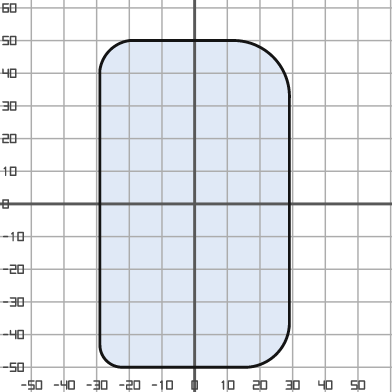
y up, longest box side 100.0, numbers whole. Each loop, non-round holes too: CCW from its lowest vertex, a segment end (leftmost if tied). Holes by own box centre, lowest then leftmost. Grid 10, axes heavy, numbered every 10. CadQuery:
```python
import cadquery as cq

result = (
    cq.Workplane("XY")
    .moveTo(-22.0, -50.0)
    .lineTo(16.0, -50.0)
    .threePointArc((25.0, -46.0), (29.0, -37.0))
    .lineTo(29.0, 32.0)
    .threePointArc((24.0, 45.0), (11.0, 50.0))
    .lineTo(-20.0, 50.0)
    .threePointArc((-26.0, 47.0), (-29.0, 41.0))
    .lineTo(-29.0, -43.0)
    .threePointArc((-27.0, -48.0), (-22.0, -50.0))
    .close()
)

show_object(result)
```